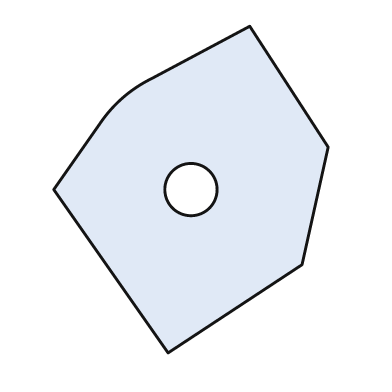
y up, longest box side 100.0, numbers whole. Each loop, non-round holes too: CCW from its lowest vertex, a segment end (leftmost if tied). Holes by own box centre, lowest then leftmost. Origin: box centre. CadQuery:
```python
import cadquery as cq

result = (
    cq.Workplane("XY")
    .moveTo(-7.0, -50.0)
    .lineTo(34.0, -23.0)
    .lineTo(42.0, 13.0)
    .lineTo(18.0, 50.0)
    .lineTo(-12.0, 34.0)
    .threePointArc((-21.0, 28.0), (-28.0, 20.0))
    .lineTo(-42.0, 0.0)
    .close()
    .moveTo(0.0, 0.0)
    .circle(8.0)
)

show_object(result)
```